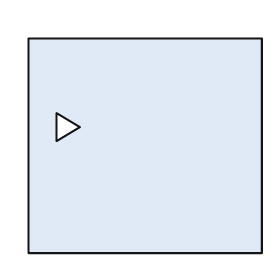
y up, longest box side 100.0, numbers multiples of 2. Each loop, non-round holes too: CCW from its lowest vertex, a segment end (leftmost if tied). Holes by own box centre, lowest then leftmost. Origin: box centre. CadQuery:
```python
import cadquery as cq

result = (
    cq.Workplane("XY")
    .moveTo(-50.0, -46.0)
    .lineTo(50.0, -46.0)
    .lineTo(50.0, 46.0)
    .lineTo(-50.0, 46.0)
    .close()
    .moveTo(-38.0, 2.0)
    .lineTo(-28.0, 8.0)
    .lineTo(-38.0, 14.0)
    .close()
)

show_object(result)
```